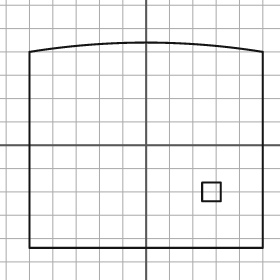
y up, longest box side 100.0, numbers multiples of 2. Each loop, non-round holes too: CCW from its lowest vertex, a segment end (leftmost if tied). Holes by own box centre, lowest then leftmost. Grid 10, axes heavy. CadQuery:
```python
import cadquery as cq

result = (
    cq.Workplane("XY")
    .moveTo(-50.0, -44.0)
    .lineTo(50.0, -44.0)
    .lineTo(50.0, 40.0)
    .threePointArc((0.0, 44.0), (-50.0, 40.0))
    .close()
    .moveTo(24.0, -24.0)
    .lineTo(32.0, -24.0)
    .lineTo(32.0, -16.0)
    .lineTo(24.0, -16.0)
    .close()
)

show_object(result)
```